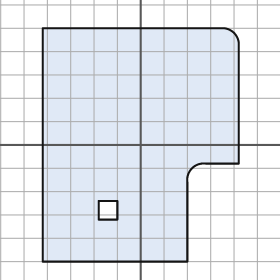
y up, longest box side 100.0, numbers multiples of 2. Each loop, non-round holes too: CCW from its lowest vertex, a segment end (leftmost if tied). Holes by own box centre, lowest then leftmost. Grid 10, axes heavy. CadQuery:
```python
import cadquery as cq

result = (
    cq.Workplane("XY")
    .moveTo(-42.0, -50.0)
    .lineTo(20.0, -50.0)
    .lineTo(20.0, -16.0)
    .threePointArc((22.0, -10.0), (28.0, -8.0))
    .lineTo(42.0, -8.0)
    .lineTo(42.0, 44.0)
    .threePointArc((40.0, 48.0), (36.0, 50.0))
    .lineTo(-42.0, 50.0)
    .close()
    .moveTo(-18.0, -32.0)
    .lineTo(-10.0, -32.0)
    .lineTo(-10.0, -24.0)
    .lineTo(-18.0, -24.0)
    .close()
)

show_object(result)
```